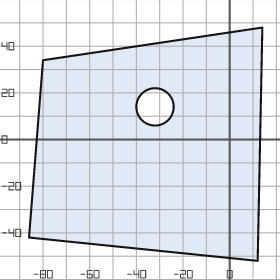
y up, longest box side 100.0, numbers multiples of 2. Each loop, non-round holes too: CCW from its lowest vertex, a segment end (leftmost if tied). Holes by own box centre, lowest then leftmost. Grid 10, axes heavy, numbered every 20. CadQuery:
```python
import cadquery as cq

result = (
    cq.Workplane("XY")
    .moveTo(12.0, -52.0)
    .lineTo(14.0, 48.0)
    .lineTo(-80.0, 34.0)
    .lineTo(-86.0, -42.0)
    .close()
    .moveTo(-32.0, 14.0)
    .circle(8.0)
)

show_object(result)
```